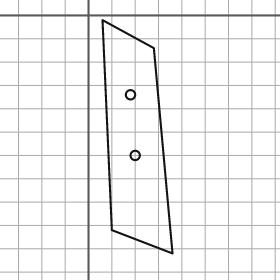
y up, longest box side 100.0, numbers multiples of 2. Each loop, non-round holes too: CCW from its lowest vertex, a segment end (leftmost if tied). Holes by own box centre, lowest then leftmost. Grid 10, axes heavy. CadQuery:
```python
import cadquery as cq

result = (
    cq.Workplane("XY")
    .moveTo(36.0, -102.0)
    .lineTo(28.0, -14.0)
    .lineTo(6.0, -2.0)
    .lineTo(10.0, -92.0)
    .close()
    .moveTo(20.0, -60.0)
    .circle(2.0)
    .moveTo(18.0, -34.0)
    .circle(2.0)
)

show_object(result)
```